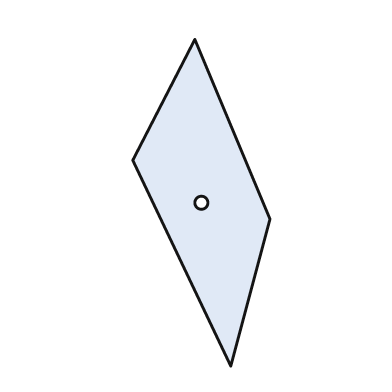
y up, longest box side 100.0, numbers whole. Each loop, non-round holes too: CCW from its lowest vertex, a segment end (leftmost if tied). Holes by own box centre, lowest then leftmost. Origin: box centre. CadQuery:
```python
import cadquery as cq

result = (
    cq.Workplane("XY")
    .moveTo(9.0, -50.0)
    .lineTo(21.0, -5.0)
    .lineTo(-2.0, 50.0)
    .lineTo(-21.0, 13.0)
    .close()
    .moveTo(0.0, 0.0)
    .circle(2.0)
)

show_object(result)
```